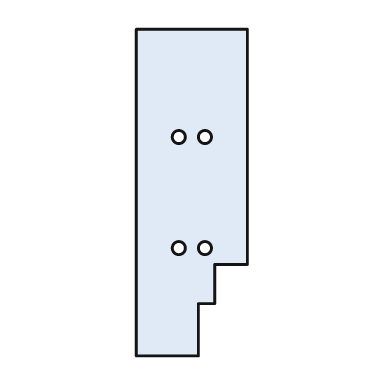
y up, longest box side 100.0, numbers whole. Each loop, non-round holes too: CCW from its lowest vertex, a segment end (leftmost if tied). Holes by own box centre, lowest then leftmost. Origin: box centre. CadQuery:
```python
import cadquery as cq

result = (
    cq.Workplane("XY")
    .moveTo(-17.0, -50.0)
    .lineTo(2.0, -50.0)
    .lineTo(2.0, -34.0)
    .lineTo(7.0, -34.0)
    .lineTo(7.0, -22.0)
    .lineTo(17.0, -22.0)
    .lineTo(17.0, 50.0)
    .lineTo(-17.0, 50.0)
    .close()
    .moveTo(-4.0, -17.0)
    .circle(2.0)
    .moveTo(4.0, -17.0)
    .circle(2.0)
    .moveTo(-4.0, 17.0)
    .circle(2.0)
    .moveTo(4.0, 17.0)
    .circle(2.0)
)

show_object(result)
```